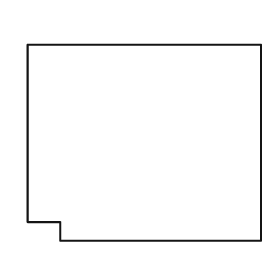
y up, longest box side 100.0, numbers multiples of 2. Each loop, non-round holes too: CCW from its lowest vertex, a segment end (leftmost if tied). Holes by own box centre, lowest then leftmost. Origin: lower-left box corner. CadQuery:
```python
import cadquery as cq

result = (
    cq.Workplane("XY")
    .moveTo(14.0, 0.0)
    .lineTo(100.0, 0.0)
    .lineTo(100.0, 84.0)
    .lineTo(0.0, 84.0)
    .lineTo(0.0, 8.0)
    .lineTo(14.0, 8.0)
    .close()
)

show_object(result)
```